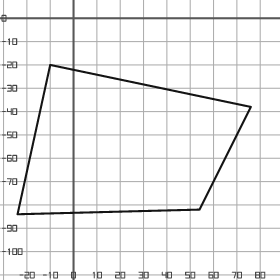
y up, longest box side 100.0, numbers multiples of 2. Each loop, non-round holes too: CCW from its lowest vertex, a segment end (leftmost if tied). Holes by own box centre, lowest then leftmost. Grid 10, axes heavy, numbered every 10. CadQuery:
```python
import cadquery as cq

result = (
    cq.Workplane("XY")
    .moveTo(-24.0, -84.0)
    .lineTo(54.0, -82.0)
    .lineTo(76.0, -38.0)
    .lineTo(-10.0, -20.0)
    .close()
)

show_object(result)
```